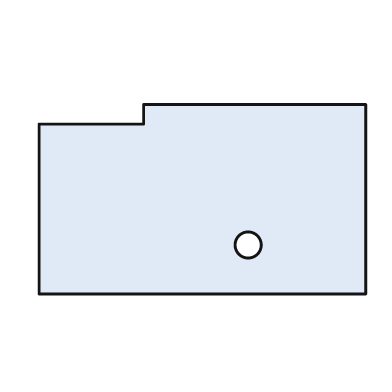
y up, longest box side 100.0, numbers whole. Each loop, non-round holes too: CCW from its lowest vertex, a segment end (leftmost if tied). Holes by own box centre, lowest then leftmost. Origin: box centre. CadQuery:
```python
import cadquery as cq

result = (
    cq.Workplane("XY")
    .moveTo(-50.0, -29.0)
    .lineTo(50.0, -29.0)
    .lineTo(50.0, 29.0)
    .lineTo(-18.0, 29.0)
    .lineTo(-18.0, 23.0)
    .lineTo(-50.0, 23.0)
    .close()
    .moveTo(14.0, -14.0)
    .circle(4.0)
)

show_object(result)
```